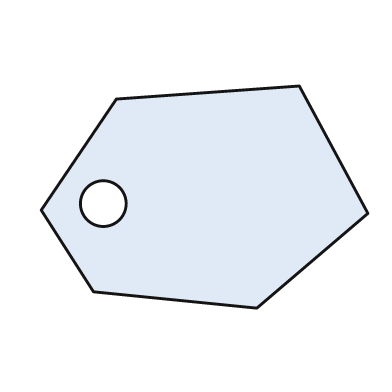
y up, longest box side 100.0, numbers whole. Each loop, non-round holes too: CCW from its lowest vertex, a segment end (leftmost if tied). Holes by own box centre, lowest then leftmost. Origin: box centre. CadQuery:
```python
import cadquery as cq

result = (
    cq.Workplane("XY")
    .moveTo(16.0, -34.0)
    .lineTo(50.0, -5.0)
    .lineTo(29.0, 34.0)
    .lineTo(-27.0, 30.0)
    .lineTo(-50.0, -4.0)
    .lineTo(-34.0, -29.0)
    .close()
    .moveTo(-31.0, -2.0)
    .circle(7.0)
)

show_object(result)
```